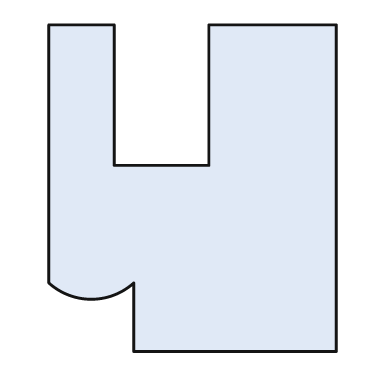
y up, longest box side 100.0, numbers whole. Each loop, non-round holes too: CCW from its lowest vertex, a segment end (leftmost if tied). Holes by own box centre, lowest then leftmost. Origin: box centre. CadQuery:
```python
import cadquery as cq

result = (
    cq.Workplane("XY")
    .moveTo(-18.0, -50.0)
    .lineTo(44.0, -50.0)
    .lineTo(44.0, 50.0)
    .lineTo(5.0, 50.0)
    .lineTo(5.0, 7.0)
    .lineTo(-24.0, 7.0)
    .lineTo(-24.0, 50.0)
    .lineTo(-44.0, 50.0)
    .lineTo(-44.0, -29.0)
    .threePointArc((-31.0, -34.0), (-18.0, -29.0))
    .close()
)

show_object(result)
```